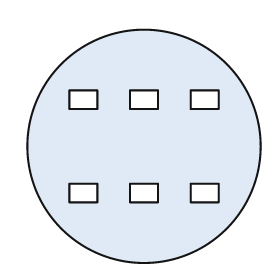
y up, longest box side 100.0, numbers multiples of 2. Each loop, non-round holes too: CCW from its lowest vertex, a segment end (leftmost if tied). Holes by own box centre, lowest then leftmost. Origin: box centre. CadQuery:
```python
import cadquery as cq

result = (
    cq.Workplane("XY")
    .moveTo(0.0, 0.0)
    .circle(50.0)
    .moveTo(-32.0, -24.0)
    .lineTo(-20.0, -24.0)
    .lineTo(-20.0, -16.0)
    .lineTo(-32.0, -16.0)
    .close()
    .moveTo(-6.0, -24.0)
    .lineTo(6.0, -24.0)
    .lineTo(6.0, -16.0)
    .lineTo(-6.0, -16.0)
    .close()
    .moveTo(20.0, -24.0)
    .lineTo(32.0, -24.0)
    .lineTo(32.0, -16.0)
    .lineTo(20.0, -16.0)
    .close()
    .moveTo(-32.0, 16.0)
    .lineTo(-20.0, 16.0)
    .lineTo(-20.0, 24.0)
    .lineTo(-32.0, 24.0)
    .close()
    .moveTo(-6.0, 16.0)
    .lineTo(6.0, 16.0)
    .lineTo(6.0, 24.0)
    .lineTo(-6.0, 24.0)
    .close()
    .moveTo(20.0, 16.0)
    .lineTo(32.0, 16.0)
    .lineTo(32.0, 24.0)
    .lineTo(20.0, 24.0)
    .close()
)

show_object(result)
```